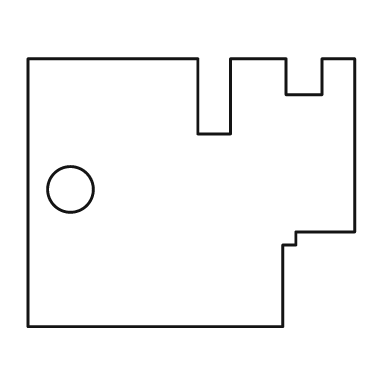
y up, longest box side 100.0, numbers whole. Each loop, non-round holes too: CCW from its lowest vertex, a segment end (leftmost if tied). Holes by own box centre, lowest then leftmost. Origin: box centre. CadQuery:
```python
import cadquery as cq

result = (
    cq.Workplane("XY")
    .moveTo(-50.0, -41.0)
    .lineTo(28.0, -41.0)
    .lineTo(28.0, -16.0)
    .lineTo(32.0, -16.0)
    .lineTo(32.0, -12.0)
    .lineTo(50.0, -12.0)
    .lineTo(50.0, 41.0)
    .lineTo(40.0, 41.0)
    .lineTo(40.0, 30.0)
    .lineTo(29.0, 30.0)
    .lineTo(29.0, 41.0)
    .lineTo(12.0, 41.0)
    .lineTo(12.0, 18.0)
    .lineTo(2.0, 18.0)
    .lineTo(2.0, 41.0)
    .lineTo(-50.0, 41.0)
    .close()
    .moveTo(-37.0, 1.0)
    .circle(7.0)
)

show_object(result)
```